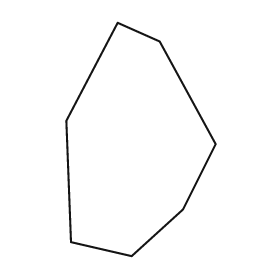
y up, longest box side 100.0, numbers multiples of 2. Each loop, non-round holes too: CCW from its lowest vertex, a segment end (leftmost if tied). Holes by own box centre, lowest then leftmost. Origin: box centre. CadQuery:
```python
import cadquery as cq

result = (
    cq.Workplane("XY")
    .moveTo(-4.0, -50.0)
    .lineTo(18.0, -30.0)
    .lineTo(32.0, -2.0)
    .lineTo(8.0, 42.0)
    .lineTo(-10.0, 50.0)
    .lineTo(-32.0, 8.0)
    .lineTo(-30.0, -44.0)
    .close()
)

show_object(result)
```